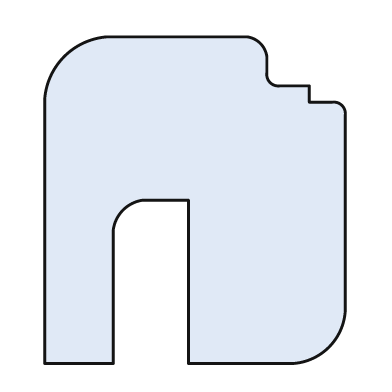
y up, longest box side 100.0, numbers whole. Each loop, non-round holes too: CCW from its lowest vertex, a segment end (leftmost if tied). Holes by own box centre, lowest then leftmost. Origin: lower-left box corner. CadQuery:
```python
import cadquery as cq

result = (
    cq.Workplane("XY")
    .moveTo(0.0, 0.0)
    .lineTo(21.0, 0.0)
    .lineTo(21.0, 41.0)
    .threePointArc((24.0, 47.0), (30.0, 50.0))
    .lineTo(44.0, 50.0)
    .lineTo(44.0, 0.0)
    .lineTo(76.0, 0.0)
    .threePointArc((87.0, 5.0), (92.0, 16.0))
    .lineTo(92.0, 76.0)
    .threePointArc((91.0, 79.0), (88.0, 80.0))
    .lineTo(81.0, 80.0)
    .lineTo(81.0, 85.0)
    .lineTo(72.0, 85.0)
    .threePointArc((69.0, 86.0), (68.0, 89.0))
    .lineTo(68.0, 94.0)
    .threePointArc((66.0, 98.0), (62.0, 100.0))
    .lineTo(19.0, 100.0)
    .threePointArc((6.0, 94.0), (0.0, 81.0))
    .close()
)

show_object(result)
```